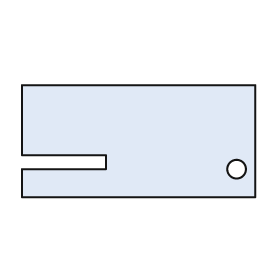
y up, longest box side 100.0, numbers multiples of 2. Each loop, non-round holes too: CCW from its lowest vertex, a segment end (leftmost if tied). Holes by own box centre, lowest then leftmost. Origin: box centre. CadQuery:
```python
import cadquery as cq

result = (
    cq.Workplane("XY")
    .moveTo(-50.0, -24.0)
    .lineTo(50.0, -24.0)
    .lineTo(50.0, 24.0)
    .lineTo(-50.0, 24.0)
    .lineTo(-50.0, -6.0)
    .lineTo(-14.0, -6.0)
    .lineTo(-14.0, -12.0)
    .lineTo(-50.0, -12.0)
    .close()
    .moveTo(42.0, -12.0)
    .circle(4.0)
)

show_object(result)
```